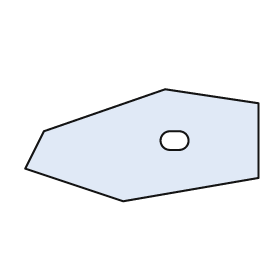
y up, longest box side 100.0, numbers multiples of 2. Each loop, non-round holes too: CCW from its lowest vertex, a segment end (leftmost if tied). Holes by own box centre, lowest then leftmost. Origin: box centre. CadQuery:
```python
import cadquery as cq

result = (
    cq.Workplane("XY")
    .moveTo(-8.0, -24.0)
    .lineTo(50.0, -14.0)
    .lineTo(50.0, 18.0)
    .lineTo(10.0, 24.0)
    .lineTo(-42.0, 6.0)
    .lineTo(-50.0, -10.0)
    .close()
    .moveTo(12.0, -2.0)
    .lineTo(16.0, -2.0)
    .threePointArc((20.0, 2.0), (16.0, 6.0))
    .lineTo(12.0, 6.0)
    .threePointArc((8.0, 2.0), (12.0, -2.0))
    .close()
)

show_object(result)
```